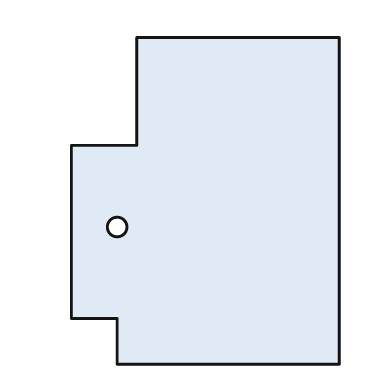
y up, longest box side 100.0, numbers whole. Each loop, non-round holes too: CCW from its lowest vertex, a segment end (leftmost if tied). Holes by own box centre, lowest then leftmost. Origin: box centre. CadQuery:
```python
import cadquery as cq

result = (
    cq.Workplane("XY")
    .moveTo(-27.0, -50.0)
    .lineTo(41.0, -50.0)
    .lineTo(41.0, 50.0)
    .lineTo(-21.0, 50.0)
    .lineTo(-21.0, 17.0)
    .lineTo(-41.0, 17.0)
    .lineTo(-41.0, -36.0)
    .lineTo(-27.0, -36.0)
    .close()
    .moveTo(-27.0, -8.0)
    .circle(3.0)
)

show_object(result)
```